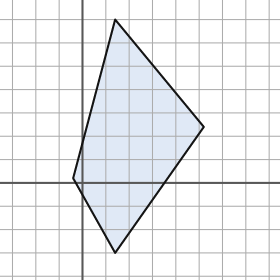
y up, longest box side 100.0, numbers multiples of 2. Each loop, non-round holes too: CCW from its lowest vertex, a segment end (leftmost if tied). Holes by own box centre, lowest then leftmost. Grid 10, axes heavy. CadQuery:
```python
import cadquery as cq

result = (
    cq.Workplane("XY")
    .moveTo(14.0, -30.0)
    .lineTo(52.0, 24.0)
    .lineTo(14.0, 70.0)
    .lineTo(-4.0, 2.0)
    .close()
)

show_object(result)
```